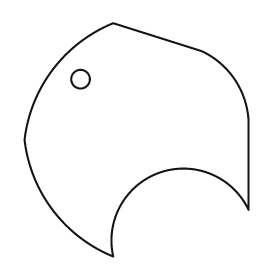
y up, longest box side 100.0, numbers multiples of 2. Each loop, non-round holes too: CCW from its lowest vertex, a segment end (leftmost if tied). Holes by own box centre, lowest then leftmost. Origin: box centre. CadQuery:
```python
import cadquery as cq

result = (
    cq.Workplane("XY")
    .moveTo(-10.0, -50.0)
    .threePointArc((10.0, -14.0), (48.0, -30.0))
    .lineTo(48.0, 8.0)
    .threePointArc((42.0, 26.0), (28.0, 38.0))
    .lineTo(-10.0, 50.0)
    .threePointArc((-36.0, 30.0), (-48.0, 0.0))
    .threePointArc((-36.0, -30.0), (-10.0, -50.0))
    .close()
    .moveTo(-24.0, 26.0)
    .circle(4.0)
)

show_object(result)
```